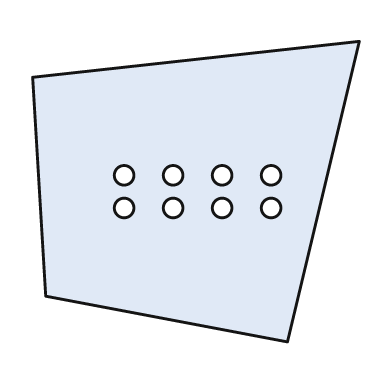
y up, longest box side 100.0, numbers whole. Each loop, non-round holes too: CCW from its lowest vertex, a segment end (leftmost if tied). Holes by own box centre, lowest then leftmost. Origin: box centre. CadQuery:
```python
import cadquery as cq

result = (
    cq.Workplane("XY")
    .moveTo(28.0, -46.0)
    .lineTo(50.0, 46.0)
    .lineTo(-50.0, 35.0)
    .lineTo(-46.0, -32.0)
    .close()
    .moveTo(-22.0, -5.0)
    .circle(3.0)
    .moveTo(-7.0, -5.0)
    .circle(3.0)
    .moveTo(8.0, -5.0)
    .circle(3.0)
    .moveTo(23.0, -5.0)
    .circle(3.0)
    .moveTo(-22.0, 5.0)
    .circle(3.0)
    .moveTo(-7.0, 5.0)
    .circle(3.0)
    .moveTo(8.0, 5.0)
    .circle(3.0)
    .moveTo(23.0, 5.0)
    .circle(3.0)
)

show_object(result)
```